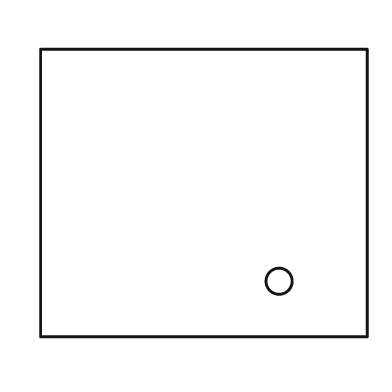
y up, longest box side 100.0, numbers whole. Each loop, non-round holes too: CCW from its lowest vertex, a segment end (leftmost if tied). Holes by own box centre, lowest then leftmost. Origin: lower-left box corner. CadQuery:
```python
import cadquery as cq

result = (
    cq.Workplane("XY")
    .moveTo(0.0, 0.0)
    .lineTo(100.0, 0.0)
    .lineTo(100.0, 88.0)
    .lineTo(0.0, 88.0)
    .close()
    .moveTo(73.0, 17.0)
    .circle(4.0)
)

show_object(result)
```